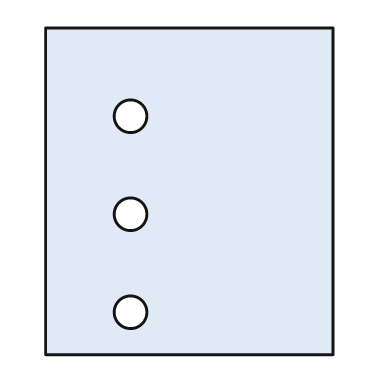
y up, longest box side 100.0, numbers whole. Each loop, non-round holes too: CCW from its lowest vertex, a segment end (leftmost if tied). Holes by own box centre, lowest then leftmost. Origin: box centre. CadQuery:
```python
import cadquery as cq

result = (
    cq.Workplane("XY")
    .moveTo(-44.0, -50.0)
    .lineTo(44.0, -50.0)
    .lineTo(44.0, 50.0)
    .lineTo(-44.0, 50.0)
    .close()
    .moveTo(-18.0, -37.0)
    .circle(5.0)
    .moveTo(-18.0, -7.0)
    .circle(5.0)
    .moveTo(-18.0, 23.0)
    .circle(5.0)
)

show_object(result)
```